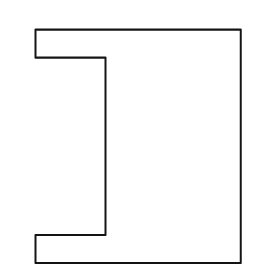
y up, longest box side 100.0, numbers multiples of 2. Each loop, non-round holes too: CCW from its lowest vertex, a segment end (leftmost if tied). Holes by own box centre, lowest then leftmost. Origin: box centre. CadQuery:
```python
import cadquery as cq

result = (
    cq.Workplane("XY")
    .moveTo(-44.0, -50.0)
    .lineTo(44.0, -50.0)
    .lineTo(44.0, 50.0)
    .lineTo(-44.0, 50.0)
    .lineTo(-44.0, 38.0)
    .lineTo(-14.0, 38.0)
    .lineTo(-14.0, -38.0)
    .lineTo(-44.0, -38.0)
    .close()
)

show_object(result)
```